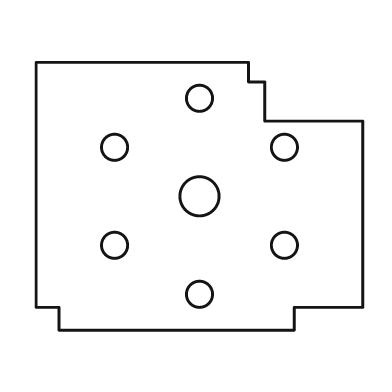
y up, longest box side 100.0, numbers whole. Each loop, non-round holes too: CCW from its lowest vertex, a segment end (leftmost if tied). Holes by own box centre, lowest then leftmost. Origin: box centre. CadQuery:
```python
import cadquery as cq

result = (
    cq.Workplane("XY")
    .moveTo(-43.0, -41.0)
    .lineTo(29.0, -41.0)
    .lineTo(29.0, -34.0)
    .lineTo(50.0, -34.0)
    .lineTo(50.0, 23.0)
    .lineTo(20.0, 23.0)
    .lineTo(20.0, 35.0)
    .lineTo(15.0, 35.0)
    .lineTo(15.0, 41.0)
    .lineTo(-50.0, 41.0)
    .lineTo(-50.0, -34.0)
    .lineTo(-43.0, -34.0)
    .close()
    .moveTo(0.0, -30.0)
    .circle(4.0)
    .moveTo(-26.0, -15.0)
    .circle(4.0)
    .moveTo(26.0, -15.0)
    .circle(4.0)
    .moveTo(0.0, 0.0)
    .circle(6.0)
    .moveTo(-26.0, 15.0)
    .circle(4.0)
    .moveTo(26.0, 15.0)
    .circle(4.0)
    .moveTo(0.0, 30.0)
    .circle(4.0)
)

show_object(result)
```